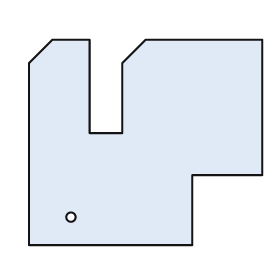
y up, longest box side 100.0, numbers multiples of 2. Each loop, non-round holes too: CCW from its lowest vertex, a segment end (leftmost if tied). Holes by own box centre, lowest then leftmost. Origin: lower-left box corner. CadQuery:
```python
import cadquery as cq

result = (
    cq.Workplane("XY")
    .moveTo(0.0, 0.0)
    .lineTo(70.0, 0.0)
    .lineTo(70.0, 30.0)
    .lineTo(100.0, 30.0)
    .lineTo(100.0, 88.0)
    .lineTo(50.0, 88.0)
    .lineTo(40.0, 78.0)
    .lineTo(40.0, 48.0)
    .lineTo(26.0, 48.0)
    .lineTo(26.0, 88.0)
    .lineTo(10.0, 88.0)
    .lineTo(0.0, 78.0)
    .close()
    .moveTo(18.0, 12.0)
    .circle(2.0)
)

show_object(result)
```